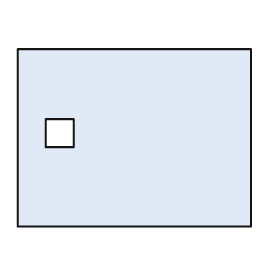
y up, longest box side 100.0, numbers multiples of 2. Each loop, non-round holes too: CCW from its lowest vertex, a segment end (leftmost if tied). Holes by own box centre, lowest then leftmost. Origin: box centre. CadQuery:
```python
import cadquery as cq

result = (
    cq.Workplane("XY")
    .moveTo(-50.0, -38.0)
    .lineTo(50.0, -38.0)
    .lineTo(50.0, 38.0)
    .lineTo(-50.0, 38.0)
    .close()
    .moveTo(-38.0, -4.0)
    .lineTo(-26.0, -4.0)
    .lineTo(-26.0, 8.0)
    .lineTo(-38.0, 8.0)
    .close()
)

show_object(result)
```